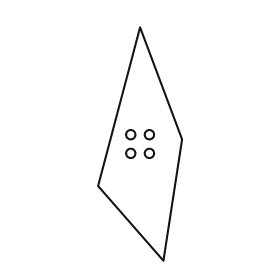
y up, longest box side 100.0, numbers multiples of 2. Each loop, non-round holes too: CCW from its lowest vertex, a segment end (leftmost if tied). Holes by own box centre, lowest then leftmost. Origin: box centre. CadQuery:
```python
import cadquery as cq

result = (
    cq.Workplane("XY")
    .moveTo(10.0, -50.0)
    .lineTo(18.0, 2.0)
    .lineTo(0.0, 50.0)
    .lineTo(-18.0, -18.0)
    .close()
    .moveTo(-4.0, -4.0)
    .circle(2.0)
    .moveTo(4.0, -4.0)
    .circle(2.0)
    .moveTo(-4.0, 4.0)
    .circle(2.0)
    .moveTo(4.0, 4.0)
    .circle(2.0)
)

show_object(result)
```